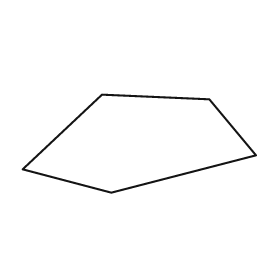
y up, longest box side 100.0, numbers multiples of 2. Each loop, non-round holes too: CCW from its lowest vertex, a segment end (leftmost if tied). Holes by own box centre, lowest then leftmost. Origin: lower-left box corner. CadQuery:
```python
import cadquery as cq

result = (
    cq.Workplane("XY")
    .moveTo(38.0, 0.0)
    .lineTo(100.0, 16.0)
    .lineTo(80.0, 40.0)
    .lineTo(34.0, 42.0)
    .lineTo(0.0, 10.0)
    .close()
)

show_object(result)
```